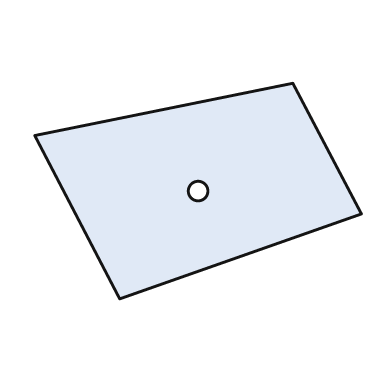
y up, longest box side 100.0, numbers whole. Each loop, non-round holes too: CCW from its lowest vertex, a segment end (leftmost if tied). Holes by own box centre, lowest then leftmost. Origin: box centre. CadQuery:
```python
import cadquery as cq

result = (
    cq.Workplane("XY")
    .moveTo(-24.0, -33.0)
    .lineTo(50.0, -7.0)
    .lineTo(29.0, 33.0)
    .lineTo(-50.0, 17.0)
    .close()
    .moveTo(0.0, 0.0)
    .circle(3.0)
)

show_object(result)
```